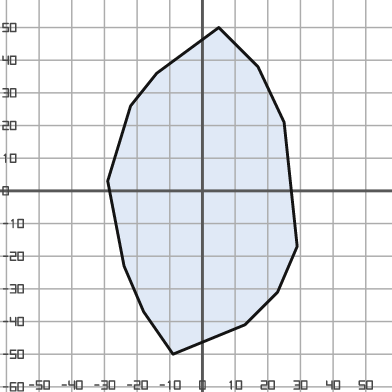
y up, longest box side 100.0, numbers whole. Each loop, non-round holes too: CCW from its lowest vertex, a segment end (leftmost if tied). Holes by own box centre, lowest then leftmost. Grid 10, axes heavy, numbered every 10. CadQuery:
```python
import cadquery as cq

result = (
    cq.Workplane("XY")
    .moveTo(-9.0, -50.0)
    .lineTo(13.0, -41.0)
    .lineTo(23.0, -31.0)
    .lineTo(29.0, -17.0)
    .lineTo(25.0, 21.0)
    .lineTo(17.0, 38.0)
    .lineTo(5.0, 50.0)
    .lineTo(-14.0, 36.0)
    .lineTo(-22.0, 26.0)
    .lineTo(-29.0, 3.0)
    .lineTo(-24.0, -23.0)
    .lineTo(-18.0, -37.0)
    .close()
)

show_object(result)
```